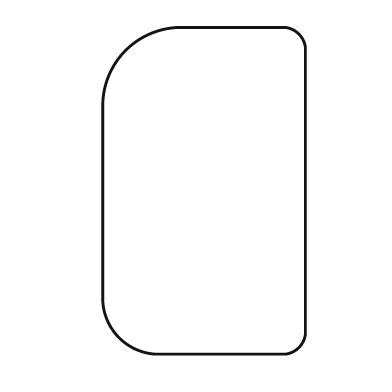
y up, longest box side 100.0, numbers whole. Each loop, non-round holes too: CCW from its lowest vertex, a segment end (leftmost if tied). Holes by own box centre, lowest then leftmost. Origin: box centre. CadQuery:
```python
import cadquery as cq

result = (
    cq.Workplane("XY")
    .moveTo(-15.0, -50.0)
    .lineTo(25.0, -50.0)
    .threePointArc((29.0, -48.0), (31.0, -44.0))
    .lineTo(31.0, 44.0)
    .threePointArc((29.0, 48.0), (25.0, 50.0))
    .lineTo(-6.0, 50.0)
    .threePointArc((-24.0, 43.0), (-31.0, 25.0))
    .lineTo(-31.0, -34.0)
    .threePointArc((-26.0, -45.0), (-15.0, -50.0))
    .close()
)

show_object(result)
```